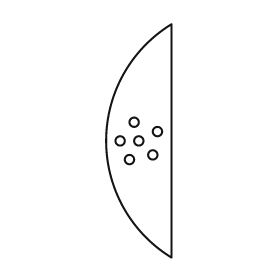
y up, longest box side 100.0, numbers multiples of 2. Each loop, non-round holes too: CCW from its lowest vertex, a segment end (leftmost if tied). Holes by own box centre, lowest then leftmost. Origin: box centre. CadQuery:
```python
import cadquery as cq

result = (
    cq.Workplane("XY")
    .moveTo(14.0, -50.0)
    .lineTo(14.0, 50.0)
    .threePointArc((-14.0, 0.0), (14.0, -50.0))
    .close()
    .moveTo(-4.0, -8.0)
    .circle(2.0)
    .moveTo(6.0, -6.0)
    .circle(2.0)
    .moveTo(-8.0, 0.0)
    .circle(2.0)
    .moveTo(0.0, 0.0)
    .circle(2.0)
    .moveTo(8.0, 4.0)
    .circle(2.0)
    .moveTo(-2.0, 8.0)
    .circle(2.0)
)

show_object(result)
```